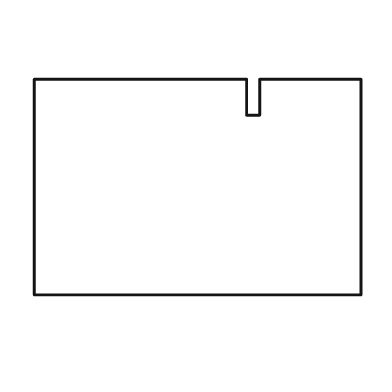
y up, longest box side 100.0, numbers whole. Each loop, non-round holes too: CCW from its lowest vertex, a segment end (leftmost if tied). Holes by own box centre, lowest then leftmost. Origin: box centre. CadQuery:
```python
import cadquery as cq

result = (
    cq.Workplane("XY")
    .moveTo(-50.0, -33.0)
    .lineTo(50.0, -33.0)
    .lineTo(50.0, 33.0)
    .lineTo(19.0, 33.0)
    .lineTo(19.0, 22.0)
    .lineTo(15.0, 22.0)
    .lineTo(15.0, 33.0)
    .lineTo(-50.0, 33.0)
    .close()
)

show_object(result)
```